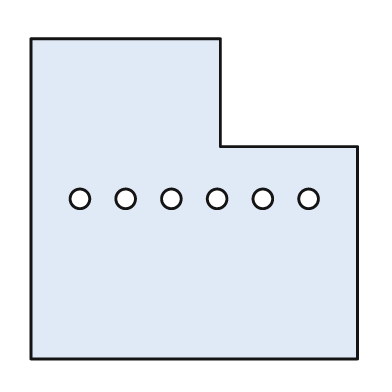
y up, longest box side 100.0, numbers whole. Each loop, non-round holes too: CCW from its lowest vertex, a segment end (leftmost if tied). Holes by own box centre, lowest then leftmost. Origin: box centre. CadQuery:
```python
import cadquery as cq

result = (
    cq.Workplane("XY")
    .moveTo(-50.0, -49.0)
    .lineTo(50.0, -49.0)
    .lineTo(50.0, 16.0)
    .lineTo(8.0, 16.0)
    .lineTo(8.0, 49.0)
    .lineTo(-50.0, 49.0)
    .close()
    .moveTo(-35.0, 0.0)
    .circle(3.0)
    .moveTo(-21.0, 0.0)
    .circle(3.0)
    .moveTo(-7.0, 0.0)
    .circle(3.0)
    .moveTo(7.0, 0.0)
    .circle(3.0)
    .moveTo(21.0, 0.0)
    .circle(3.0)
    .moveTo(35.0, 0.0)
    .circle(3.0)
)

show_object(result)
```